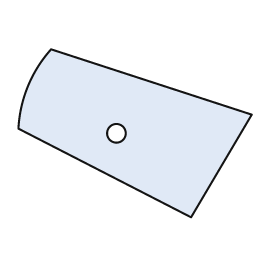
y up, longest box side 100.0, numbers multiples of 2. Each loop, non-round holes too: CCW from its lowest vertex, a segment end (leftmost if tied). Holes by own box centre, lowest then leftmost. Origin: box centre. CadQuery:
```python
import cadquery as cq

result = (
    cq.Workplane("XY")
    .moveTo(24.0, -36.0)
    .lineTo(50.0, 8.0)
    .lineTo(-36.0, 36.0)
    .threePointArc((-46.0, 20.0), (-50.0, 2.0))
    .close()
    .moveTo(-8.0, 0.0)
    .circle(4.0)
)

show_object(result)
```